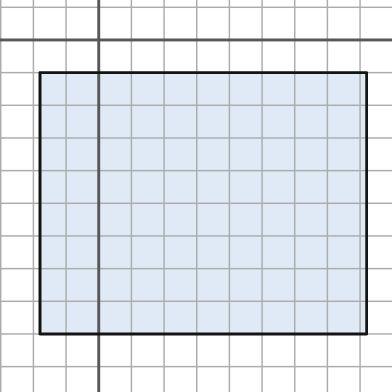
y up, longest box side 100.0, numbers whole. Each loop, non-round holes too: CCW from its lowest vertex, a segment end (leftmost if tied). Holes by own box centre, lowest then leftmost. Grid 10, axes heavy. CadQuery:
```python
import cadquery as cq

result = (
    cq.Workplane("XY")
    .moveTo(-18.0, -90.0)
    .lineTo(82.0, -90.0)
    .lineTo(82.0, -10.0)
    .lineTo(-18.0, -10.0)
    .close()
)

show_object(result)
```